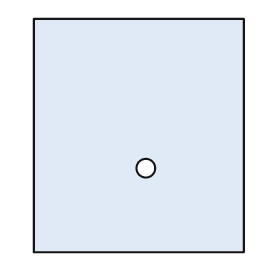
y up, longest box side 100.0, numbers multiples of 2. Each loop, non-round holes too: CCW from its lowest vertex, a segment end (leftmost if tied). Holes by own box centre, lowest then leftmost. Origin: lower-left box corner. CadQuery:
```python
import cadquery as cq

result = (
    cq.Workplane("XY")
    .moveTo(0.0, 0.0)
    .lineTo(90.0, 0.0)
    .lineTo(90.0, 100.0)
    .lineTo(0.0, 100.0)
    .close()
    .moveTo(48.0, 36.0)
    .circle(4.0)
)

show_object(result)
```